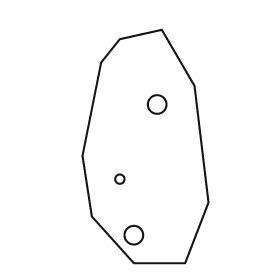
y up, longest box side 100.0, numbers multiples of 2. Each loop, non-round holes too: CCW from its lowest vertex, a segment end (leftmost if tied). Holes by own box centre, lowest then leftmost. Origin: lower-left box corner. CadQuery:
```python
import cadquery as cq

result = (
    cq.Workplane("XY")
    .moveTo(22.0, 0.0)
    .lineTo(44.0, 0.0)
    .lineTo(54.0, 26.0)
    .lineTo(48.0, 76.0)
    .lineTo(34.0, 100.0)
    .lineTo(16.0, 96.0)
    .lineTo(8.0, 86.0)
    .lineTo(0.0, 46.0)
    .lineTo(4.0, 20.0)
    .close()
    .moveTo(22.0, 12.0)
    .circle(4.0)
    .moveTo(16.0, 36.0)
    .circle(2.0)
    .moveTo(32.0, 68.0)
    .circle(4.0)
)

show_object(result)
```